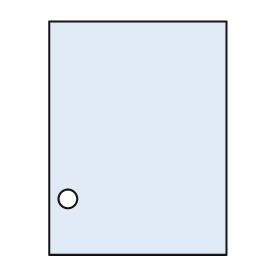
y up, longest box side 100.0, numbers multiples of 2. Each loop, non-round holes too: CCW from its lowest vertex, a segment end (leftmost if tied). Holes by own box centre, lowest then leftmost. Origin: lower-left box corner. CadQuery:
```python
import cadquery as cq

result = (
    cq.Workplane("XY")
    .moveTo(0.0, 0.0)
    .lineTo(76.0, 0.0)
    .lineTo(76.0, 100.0)
    .lineTo(0.0, 100.0)
    .close()
    .moveTo(8.0, 24.0)
    .circle(4.0)
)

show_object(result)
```